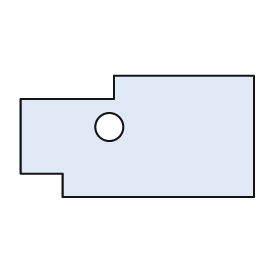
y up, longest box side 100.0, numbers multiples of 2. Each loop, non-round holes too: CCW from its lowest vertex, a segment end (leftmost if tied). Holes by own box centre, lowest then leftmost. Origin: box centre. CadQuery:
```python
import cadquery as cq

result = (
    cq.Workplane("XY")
    .moveTo(-32.0, -26.0)
    .lineTo(50.0, -26.0)
    .lineTo(50.0, 26.0)
    .lineTo(-10.0, 26.0)
    .lineTo(-10.0, 16.0)
    .lineTo(-50.0, 16.0)
    .lineTo(-50.0, -16.0)
    .lineTo(-32.0, -16.0)
    .close()
    .moveTo(-12.0, 4.0)
    .circle(6.0)
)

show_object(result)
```